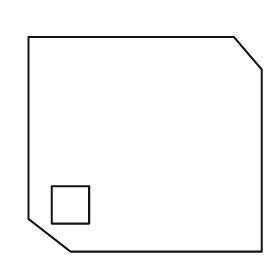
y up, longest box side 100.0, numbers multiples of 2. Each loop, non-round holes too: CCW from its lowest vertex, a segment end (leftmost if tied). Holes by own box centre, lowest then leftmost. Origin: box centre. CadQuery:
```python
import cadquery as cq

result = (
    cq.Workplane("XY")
    .moveTo(-32.0, -46.0)
    .lineTo(50.0, -46.0)
    .lineTo(50.0, 32.0)
    .lineTo(38.0, 46.0)
    .lineTo(-50.0, 46.0)
    .lineTo(-50.0, -32.0)
    .close()
    .moveTo(-40.0, -34.0)
    .lineTo(-24.0, -34.0)
    .lineTo(-24.0, -18.0)
    .lineTo(-40.0, -18.0)
    .close()
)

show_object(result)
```